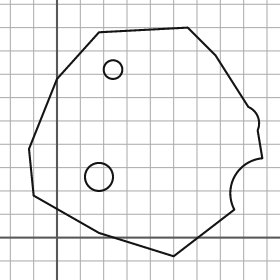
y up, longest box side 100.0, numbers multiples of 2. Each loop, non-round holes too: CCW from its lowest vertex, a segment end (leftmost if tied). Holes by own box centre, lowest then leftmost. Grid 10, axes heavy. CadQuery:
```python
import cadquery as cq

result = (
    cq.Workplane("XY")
    .moveTo(50.0, -8.0)
    .lineTo(76.0, 12.0)
    .threePointArc((76.0, 26.0), (88.0, 34.0))
    .lineTo(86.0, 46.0)
    .threePointArc((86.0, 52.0), (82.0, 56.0))
    .lineTo(68.0, 78.0)
    .lineTo(56.0, 90.0)
    .lineTo(18.0, 88.0)
    .lineTo(0.0, 68.0)
    .lineTo(-12.0, 38.0)
    .lineTo(-10.0, 18.0)
    .lineTo(18.0, 2.0)
    .close()
    .moveTo(18.0, 26.0)
    .circle(6.0)
    .moveTo(24.0, 72.0)
    .circle(4.0)
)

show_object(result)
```